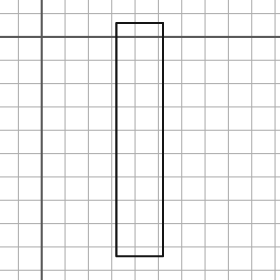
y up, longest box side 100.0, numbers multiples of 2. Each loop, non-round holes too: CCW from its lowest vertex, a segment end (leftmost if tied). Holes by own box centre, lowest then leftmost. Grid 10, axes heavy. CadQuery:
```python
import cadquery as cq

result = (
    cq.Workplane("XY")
    .moveTo(32.0, -94.0)
    .lineTo(52.0, -94.0)
    .lineTo(52.0, 6.0)
    .lineTo(32.0, 6.0)
    .close()
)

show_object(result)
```